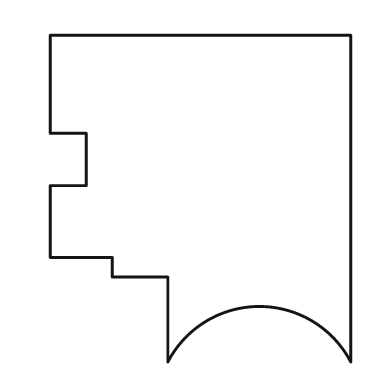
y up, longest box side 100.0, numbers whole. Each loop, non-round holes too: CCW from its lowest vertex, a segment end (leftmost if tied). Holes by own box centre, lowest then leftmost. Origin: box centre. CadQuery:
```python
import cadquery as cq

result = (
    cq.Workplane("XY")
    .moveTo(-10.0, -50.0)
    .threePointArc((18.0, -33.0), (46.0, -50.0))
    .lineTo(46.0, 50.0)
    .lineTo(-46.0, 50.0)
    .lineTo(-46.0, 20.0)
    .lineTo(-35.0, 20.0)
    .lineTo(-35.0, 4.0)
    .lineTo(-46.0, 4.0)
    .lineTo(-46.0, -18.0)
    .lineTo(-27.0, -18.0)
    .lineTo(-27.0, -24.0)
    .lineTo(-10.0, -24.0)
    .close()
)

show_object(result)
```